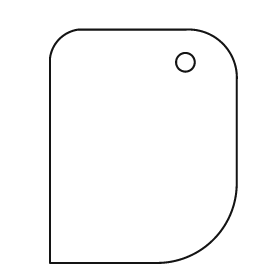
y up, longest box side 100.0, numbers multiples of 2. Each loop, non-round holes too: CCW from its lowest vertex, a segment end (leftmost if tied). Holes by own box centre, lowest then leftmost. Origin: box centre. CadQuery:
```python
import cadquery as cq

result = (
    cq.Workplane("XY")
    .moveTo(-40.0, -50.0)
    .lineTo(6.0, -50.0)
    .threePointArc((30.0, -40.0), (40.0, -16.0))
    .lineTo(40.0, 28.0)
    .threePointArc((34.0, 44.0), (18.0, 50.0))
    .lineTo(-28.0, 50.0)
    .threePointArc((-36.0, 46.0), (-40.0, 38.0))
    .close()
    .moveTo(18.0, 36.0)
    .circle(4.0)
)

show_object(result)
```